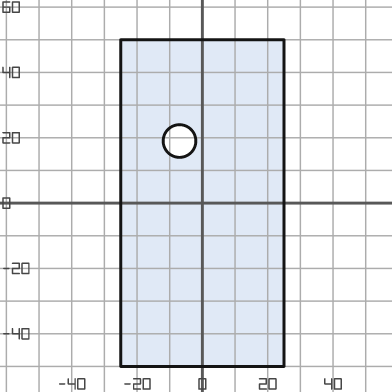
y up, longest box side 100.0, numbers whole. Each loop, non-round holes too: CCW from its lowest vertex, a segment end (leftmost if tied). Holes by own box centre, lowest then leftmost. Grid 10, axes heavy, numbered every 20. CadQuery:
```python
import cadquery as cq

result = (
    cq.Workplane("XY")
    .moveTo(-25.0, -50.0)
    .lineTo(25.0, -50.0)
    .lineTo(25.0, 50.0)
    .lineTo(-25.0, 50.0)
    .close()
    .moveTo(-7.0, 19.0)
    .circle(5.0)
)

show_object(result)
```